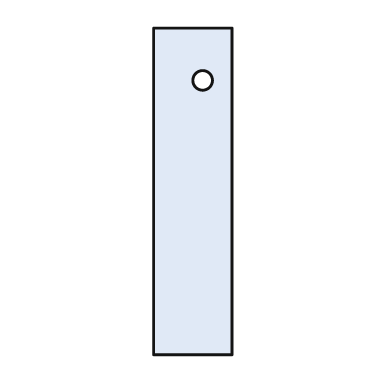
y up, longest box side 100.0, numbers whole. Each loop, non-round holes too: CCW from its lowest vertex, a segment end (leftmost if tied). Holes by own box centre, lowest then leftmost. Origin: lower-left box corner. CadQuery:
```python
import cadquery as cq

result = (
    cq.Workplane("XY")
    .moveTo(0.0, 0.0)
    .lineTo(24.0, 0.0)
    .lineTo(24.0, 100.0)
    .lineTo(0.0, 100.0)
    .close()
    .moveTo(15.0, 84.0)
    .circle(3.0)
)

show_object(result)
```